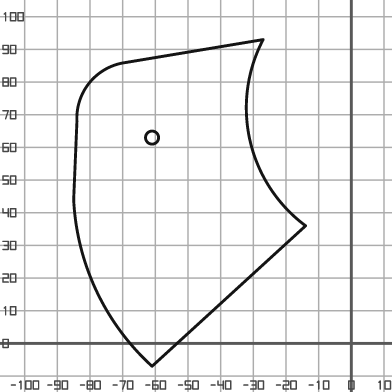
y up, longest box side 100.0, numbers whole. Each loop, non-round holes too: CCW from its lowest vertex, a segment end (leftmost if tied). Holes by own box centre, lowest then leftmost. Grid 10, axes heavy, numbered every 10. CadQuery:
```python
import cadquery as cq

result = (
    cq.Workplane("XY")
    .moveTo(-61.0, -7.0)
    .lineTo(-14.0, 36.0)
    .threePointArc((-31.0, 62.0), (-27.0, 93.0))
    .lineTo(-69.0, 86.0)
    .threePointArc((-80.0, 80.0), (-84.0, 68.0))
    .lineTo(-85.0, 44.0)
    .threePointArc((-78.0, 16.0), (-61.0, -7.0))
    .close()
    .moveTo(-61.0, 63.0)
    .circle(2.0)
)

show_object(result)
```